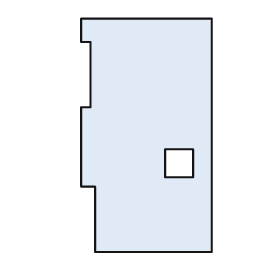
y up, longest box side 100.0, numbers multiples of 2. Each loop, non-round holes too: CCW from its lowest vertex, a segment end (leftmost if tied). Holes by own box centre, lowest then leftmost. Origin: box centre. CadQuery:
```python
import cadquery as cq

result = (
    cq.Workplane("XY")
    .moveTo(-22.0, -50.0)
    .lineTo(28.0, -50.0)
    .lineTo(28.0, 50.0)
    .lineTo(-28.0, 50.0)
    .lineTo(-28.0, 40.0)
    .lineTo(-24.0, 40.0)
    .lineTo(-24.0, 12.0)
    .lineTo(-28.0, 12.0)
    .lineTo(-28.0, -22.0)
    .lineTo(-22.0, -22.0)
    .close()
    .moveTo(8.0, -18.0)
    .lineTo(20.0, -18.0)
    .lineTo(20.0, -6.0)
    .lineTo(8.0, -6.0)
    .close()
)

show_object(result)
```